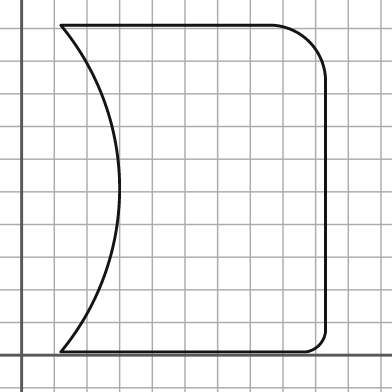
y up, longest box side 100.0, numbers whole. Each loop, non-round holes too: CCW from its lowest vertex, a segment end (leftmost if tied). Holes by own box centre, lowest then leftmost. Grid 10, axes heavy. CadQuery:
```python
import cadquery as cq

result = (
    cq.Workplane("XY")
    .moveTo(12.0, 1.0)
    .lineTo(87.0, 1.0)
    .threePointArc((91.0, 3.0), (93.0, 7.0))
    .lineTo(93.0, 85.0)
    .threePointArc((88.0, 96.0), (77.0, 101.0))
    .lineTo(12.0, 101.0)
    .threePointArc((30.0, 51.0), (12.0, 1.0))
    .close()
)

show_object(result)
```